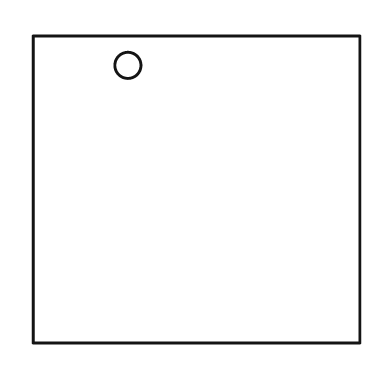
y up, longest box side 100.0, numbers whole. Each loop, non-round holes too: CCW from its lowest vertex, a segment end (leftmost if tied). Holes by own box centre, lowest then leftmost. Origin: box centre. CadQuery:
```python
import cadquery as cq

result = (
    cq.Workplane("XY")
    .moveTo(-50.0, -47.0)
    .lineTo(50.0, -47.0)
    .lineTo(50.0, 47.0)
    .lineTo(-50.0, 47.0)
    .close()
    .moveTo(-21.0, 38.0)
    .circle(4.0)
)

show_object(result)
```